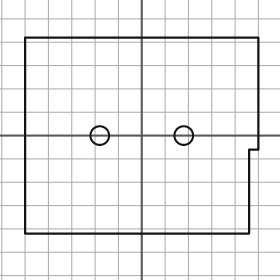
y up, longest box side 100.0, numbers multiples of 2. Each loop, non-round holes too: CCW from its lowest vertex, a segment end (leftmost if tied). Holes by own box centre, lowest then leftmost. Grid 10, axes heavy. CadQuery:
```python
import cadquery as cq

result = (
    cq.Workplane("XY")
    .moveTo(-50.0, -42.0)
    .lineTo(46.0, -42.0)
    .lineTo(46.0, -6.0)
    .lineTo(50.0, -6.0)
    .lineTo(50.0, 42.0)
    .lineTo(-50.0, 42.0)
    .close()
    .moveTo(-18.0, 0.0)
    .circle(4.0)
    .moveTo(18.0, 0.0)
    .circle(4.0)
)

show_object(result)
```